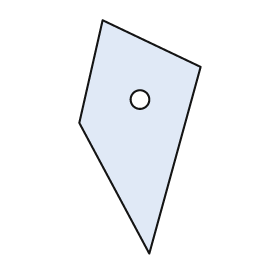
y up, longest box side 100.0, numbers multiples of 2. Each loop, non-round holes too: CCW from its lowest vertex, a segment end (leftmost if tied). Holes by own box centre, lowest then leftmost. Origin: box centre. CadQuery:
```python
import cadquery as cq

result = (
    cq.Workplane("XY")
    .moveTo(4.0, -50.0)
    .lineTo(26.0, 30.0)
    .lineTo(-16.0, 50.0)
    .lineTo(-26.0, 6.0)
    .close()
    .moveTo(0.0, 16.0)
    .circle(4.0)
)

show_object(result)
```